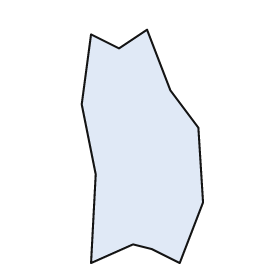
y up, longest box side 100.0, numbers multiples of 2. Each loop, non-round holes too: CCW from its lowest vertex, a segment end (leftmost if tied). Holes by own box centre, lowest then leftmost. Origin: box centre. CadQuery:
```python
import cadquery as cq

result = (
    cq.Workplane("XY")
    .moveTo(-22.0, -50.0)
    .lineTo(-4.0, -42.0)
    .lineTo(4.0, -44.0)
    .lineTo(16.0, -50.0)
    .lineTo(26.0, -24.0)
    .lineTo(24.0, 8.0)
    .lineTo(12.0, 24.0)
    .lineTo(2.0, 50.0)
    .lineTo(-10.0, 42.0)
    .lineTo(-22.0, 48.0)
    .lineTo(-26.0, 18.0)
    .lineTo(-20.0, -12.0)
    .close()
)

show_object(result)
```